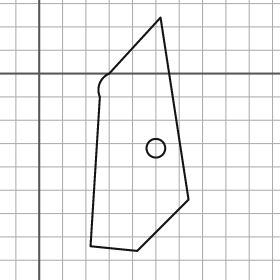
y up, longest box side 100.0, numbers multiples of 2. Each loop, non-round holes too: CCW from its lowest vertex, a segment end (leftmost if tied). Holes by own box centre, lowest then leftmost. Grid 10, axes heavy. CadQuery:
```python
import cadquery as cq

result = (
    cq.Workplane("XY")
    .moveTo(42.0, -76.0)
    .lineTo(64.0, -54.0)
    .lineTo(52.0, 24.0)
    .lineTo(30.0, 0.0)
    .threePointArc((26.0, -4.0), (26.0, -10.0))
    .lineTo(22.0, -74.0)
    .close()
    .moveTo(50.0, -32.0)
    .circle(4.0)
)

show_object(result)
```